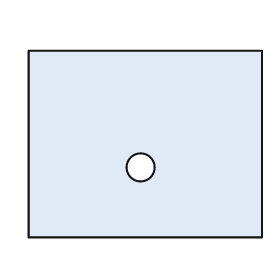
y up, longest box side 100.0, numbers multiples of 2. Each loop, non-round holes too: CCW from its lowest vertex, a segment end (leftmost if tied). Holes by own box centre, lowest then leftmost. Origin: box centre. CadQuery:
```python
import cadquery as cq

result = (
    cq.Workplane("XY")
    .moveTo(-50.0, -40.0)
    .lineTo(50.0, -40.0)
    .lineTo(50.0, 40.0)
    .lineTo(-50.0, 40.0)
    .close()
    .moveTo(-2.0, -10.0)
    .circle(6.0)
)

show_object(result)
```